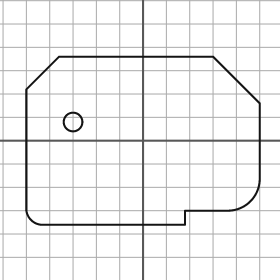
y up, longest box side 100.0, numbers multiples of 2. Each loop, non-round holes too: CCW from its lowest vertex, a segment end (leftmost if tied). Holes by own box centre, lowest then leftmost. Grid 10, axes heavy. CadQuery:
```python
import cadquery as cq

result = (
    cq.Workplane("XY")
    .moveTo(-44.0, -36.0)
    .lineTo(18.0, -36.0)
    .lineTo(18.0, -30.0)
    .lineTo(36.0, -30.0)
    .threePointArc((46.0, -26.0), (50.0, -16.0))
    .lineTo(50.0, 16.0)
    .lineTo(30.0, 36.0)
    .lineTo(-36.0, 36.0)
    .lineTo(-50.0, 22.0)
    .lineTo(-50.0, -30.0)
    .threePointArc((-48.0, -34.0), (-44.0, -36.0))
    .close()
    .moveTo(-30.0, 8.0)
    .circle(4.0)
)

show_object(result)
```